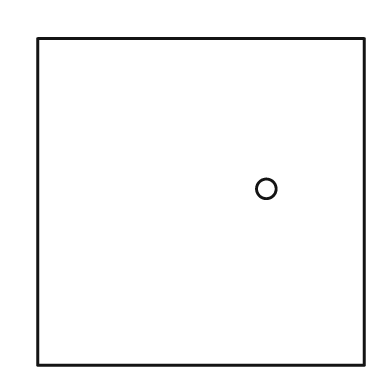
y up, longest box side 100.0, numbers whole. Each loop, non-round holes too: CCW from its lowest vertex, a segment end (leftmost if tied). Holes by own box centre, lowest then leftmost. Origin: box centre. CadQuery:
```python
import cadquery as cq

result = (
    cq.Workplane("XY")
    .moveTo(-50.0, -50.0)
    .lineTo(50.0, -50.0)
    .lineTo(50.0, 50.0)
    .lineTo(-50.0, 50.0)
    .close()
    .moveTo(20.0, 4.0)
    .circle(3.0)
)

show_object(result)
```